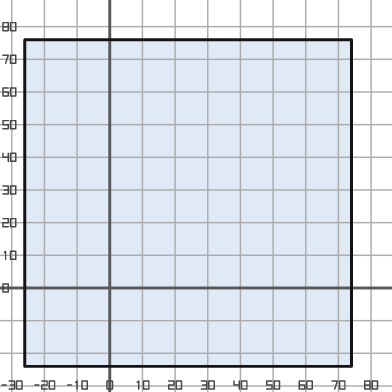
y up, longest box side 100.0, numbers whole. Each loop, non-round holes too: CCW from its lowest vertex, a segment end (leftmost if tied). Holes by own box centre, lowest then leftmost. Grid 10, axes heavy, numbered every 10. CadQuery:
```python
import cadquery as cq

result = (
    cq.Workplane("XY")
    .moveTo(-26.0, -24.0)
    .lineTo(74.0, -24.0)
    .lineTo(74.0, 76.0)
    .lineTo(-26.0, 76.0)
    .close()
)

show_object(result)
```